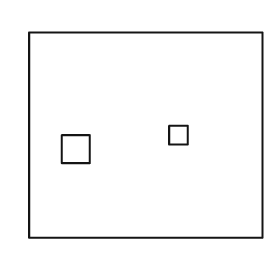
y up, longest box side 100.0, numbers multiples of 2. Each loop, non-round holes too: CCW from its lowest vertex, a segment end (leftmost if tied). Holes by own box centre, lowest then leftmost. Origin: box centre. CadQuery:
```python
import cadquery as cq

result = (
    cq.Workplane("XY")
    .moveTo(-50.0, -44.0)
    .lineTo(50.0, -44.0)
    .lineTo(50.0, 44.0)
    .lineTo(-50.0, 44.0)
    .close()
    .moveTo(-36.0, -12.0)
    .lineTo(-24.0, -12.0)
    .lineTo(-24.0, 0.0)
    .lineTo(-36.0, 0.0)
    .close()
    .moveTo(10.0, -4.0)
    .lineTo(18.0, -4.0)
    .lineTo(18.0, 4.0)
    .lineTo(10.0, 4.0)
    .close()
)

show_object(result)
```